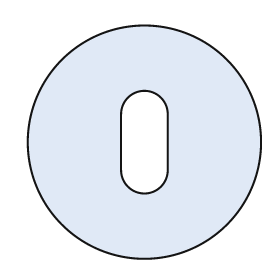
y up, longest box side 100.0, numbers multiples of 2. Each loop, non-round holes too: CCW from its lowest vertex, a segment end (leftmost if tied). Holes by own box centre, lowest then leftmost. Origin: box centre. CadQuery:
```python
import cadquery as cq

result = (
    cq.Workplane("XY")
    .moveTo(0.0, 0.0)
    .circle(50.0)
    .moveTo(-10.0, -12.0)
    .threePointArc((0.0, -22.0), (10.0, -12.0))
    .lineTo(10.0, 12.0)
    .threePointArc((0.0, 22.0), (-10.0, 12.0))
    .close()
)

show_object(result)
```